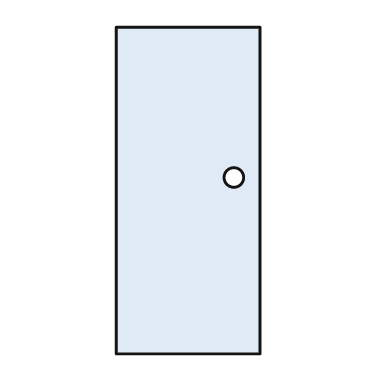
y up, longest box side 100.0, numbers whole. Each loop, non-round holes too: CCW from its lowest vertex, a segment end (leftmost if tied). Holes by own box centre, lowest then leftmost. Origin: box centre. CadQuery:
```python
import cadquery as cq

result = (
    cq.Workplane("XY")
    .moveTo(-22.0, -50.0)
    .lineTo(22.0, -50.0)
    .lineTo(22.0, 50.0)
    .lineTo(-22.0, 50.0)
    .close()
    .moveTo(14.0, 4.0)
    .circle(3.0)
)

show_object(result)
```